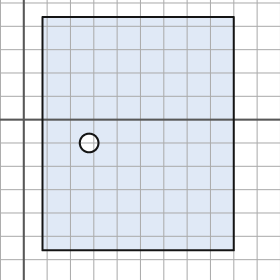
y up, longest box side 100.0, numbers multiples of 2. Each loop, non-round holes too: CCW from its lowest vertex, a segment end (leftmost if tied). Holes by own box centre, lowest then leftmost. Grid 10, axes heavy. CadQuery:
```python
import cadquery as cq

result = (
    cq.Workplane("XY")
    .moveTo(8.0, -56.0)
    .lineTo(90.0, -56.0)
    .lineTo(90.0, 44.0)
    .lineTo(8.0, 44.0)
    .close()
    .moveTo(28.0, -10.0)
    .circle(4.0)
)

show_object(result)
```